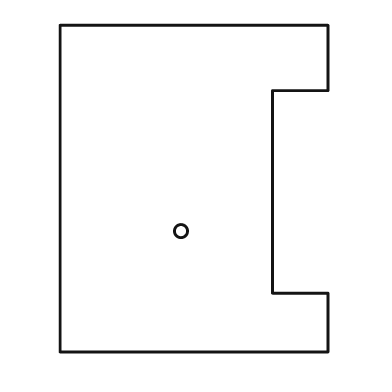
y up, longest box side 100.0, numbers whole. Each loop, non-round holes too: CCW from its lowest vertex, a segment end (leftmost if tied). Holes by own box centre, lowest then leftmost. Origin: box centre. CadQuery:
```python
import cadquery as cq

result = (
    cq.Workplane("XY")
    .moveTo(-41.0, -50.0)
    .lineTo(41.0, -50.0)
    .lineTo(41.0, -32.0)
    .lineTo(24.0, -32.0)
    .lineTo(24.0, 30.0)
    .lineTo(41.0, 30.0)
    .lineTo(41.0, 50.0)
    .lineTo(-41.0, 50.0)
    .close()
    .moveTo(-4.0, -13.0)
    .circle(2.0)
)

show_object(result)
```